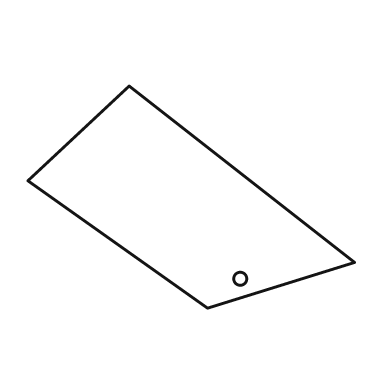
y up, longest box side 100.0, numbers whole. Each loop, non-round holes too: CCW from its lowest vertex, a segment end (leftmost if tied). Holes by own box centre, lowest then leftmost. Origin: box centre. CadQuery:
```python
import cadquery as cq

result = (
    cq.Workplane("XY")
    .moveTo(5.0, -34.0)
    .lineTo(50.0, -20.0)
    .lineTo(-19.0, 34.0)
    .lineTo(-50.0, 5.0)
    .close()
    .moveTo(15.0, -25.0)
    .circle(2.0)
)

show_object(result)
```